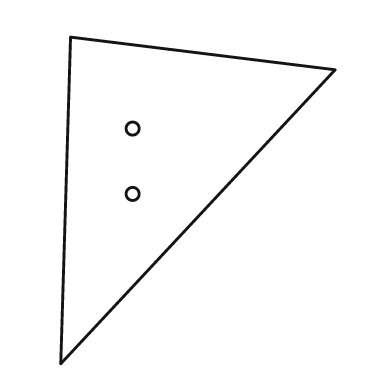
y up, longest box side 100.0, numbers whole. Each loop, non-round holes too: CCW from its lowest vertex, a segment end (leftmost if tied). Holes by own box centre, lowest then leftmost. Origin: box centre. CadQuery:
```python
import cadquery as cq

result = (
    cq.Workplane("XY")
    .moveTo(-42.0, -50.0)
    .lineTo(42.0, 40.0)
    .lineTo(-39.0, 50.0)
    .close()
    .moveTo(-20.0, 2.0)
    .circle(2.0)
    .moveTo(-20.0, 22.0)
    .circle(2.0)
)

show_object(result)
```